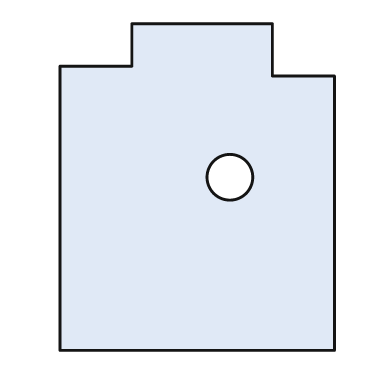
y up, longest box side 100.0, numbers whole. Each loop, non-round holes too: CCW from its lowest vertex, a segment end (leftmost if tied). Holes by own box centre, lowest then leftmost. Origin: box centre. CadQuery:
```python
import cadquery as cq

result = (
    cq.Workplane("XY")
    .moveTo(-42.0, -50.0)
    .lineTo(42.0, -50.0)
    .lineTo(42.0, 34.0)
    .lineTo(23.0, 34.0)
    .lineTo(23.0, 50.0)
    .lineTo(-20.0, 50.0)
    .lineTo(-20.0, 37.0)
    .lineTo(-42.0, 37.0)
    .close()
    .moveTo(10.0, 3.0)
    .circle(7.0)
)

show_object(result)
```